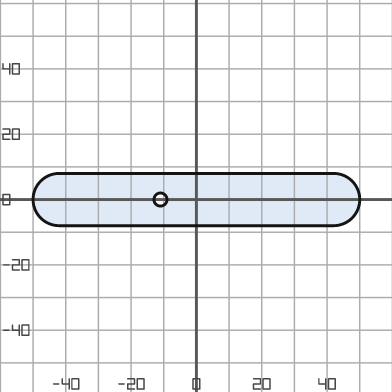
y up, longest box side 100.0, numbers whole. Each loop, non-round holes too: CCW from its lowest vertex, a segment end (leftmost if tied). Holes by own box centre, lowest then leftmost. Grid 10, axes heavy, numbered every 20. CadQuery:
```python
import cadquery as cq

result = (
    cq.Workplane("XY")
    .moveTo(-42.0, -8.0)
    .lineTo(42.0, -8.0)
    .threePointArc((50.0, 0.0), (42.0, 8.0))
    .lineTo(-42.0, 8.0)
    .threePointArc((-50.0, 0.0), (-42.0, -8.0))
    .close()
    .moveTo(-11.0, 0.0)
    .circle(2.0)
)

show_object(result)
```